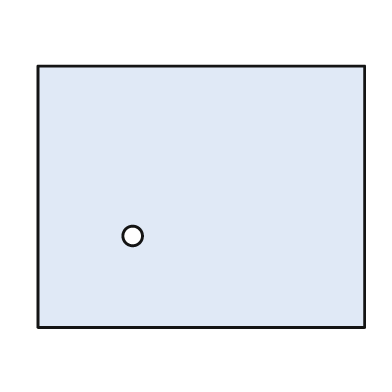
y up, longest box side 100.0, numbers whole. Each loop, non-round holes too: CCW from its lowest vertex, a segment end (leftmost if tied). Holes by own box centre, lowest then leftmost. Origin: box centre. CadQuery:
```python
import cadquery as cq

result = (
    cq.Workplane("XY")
    .moveTo(-50.0, -40.0)
    .lineTo(50.0, -40.0)
    .lineTo(50.0, 40.0)
    .lineTo(-50.0, 40.0)
    .close()
    .moveTo(-21.0, -12.0)
    .circle(3.0)
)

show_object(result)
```